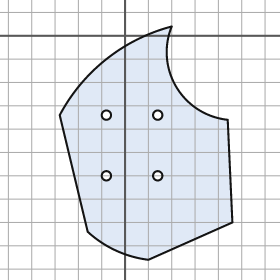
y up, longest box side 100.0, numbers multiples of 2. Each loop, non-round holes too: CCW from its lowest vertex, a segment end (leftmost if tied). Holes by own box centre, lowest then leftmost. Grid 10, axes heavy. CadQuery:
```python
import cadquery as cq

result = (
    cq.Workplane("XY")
    .moveTo(10.0, -96.0)
    .lineTo(46.0, -80.0)
    .lineTo(44.0, -36.0)
    .threePointArc((22.0, -22.0), (20.0, 4.0))
    .threePointArc((-8.0, -10.0), (-28.0, -34.0))
    .lineTo(-16.0, -84.0)
    .threePointArc((-4.0, -92.0), (10.0, -96.0))
    .close()
    .moveTo(-8.0, -60.0)
    .circle(2.0)
    .moveTo(14.0, -60.0)
    .circle(2.0)
    .moveTo(-8.0, -34.0)
    .circle(2.0)
    .moveTo(14.0, -34.0)
    .circle(2.0)
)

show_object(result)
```